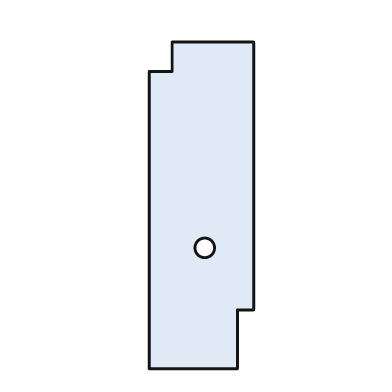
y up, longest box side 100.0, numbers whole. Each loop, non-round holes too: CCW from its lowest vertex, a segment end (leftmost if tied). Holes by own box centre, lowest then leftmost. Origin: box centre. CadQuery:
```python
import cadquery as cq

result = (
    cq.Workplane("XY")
    .moveTo(-16.0, -50.0)
    .lineTo(11.0, -50.0)
    .lineTo(11.0, -32.0)
    .lineTo(16.0, -32.0)
    .lineTo(16.0, 50.0)
    .lineTo(-9.0, 50.0)
    .lineTo(-9.0, 41.0)
    .lineTo(-16.0, 41.0)
    .close()
    .moveTo(1.0, -13.0)
    .circle(3.0)
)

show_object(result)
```